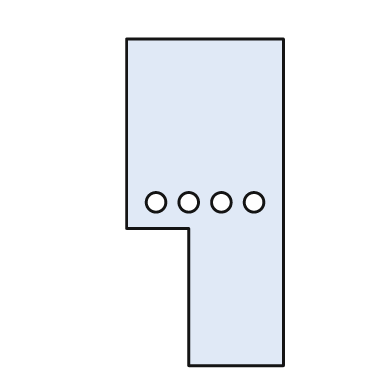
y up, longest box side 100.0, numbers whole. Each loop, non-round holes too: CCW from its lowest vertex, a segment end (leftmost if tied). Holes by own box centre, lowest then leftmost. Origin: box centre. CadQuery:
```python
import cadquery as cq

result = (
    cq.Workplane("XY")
    .moveTo(-5.0, -50.0)
    .lineTo(24.0, -50.0)
    .lineTo(24.0, 50.0)
    .lineTo(-24.0, 50.0)
    .lineTo(-24.0, -8.0)
    .lineTo(-5.0, -8.0)
    .close()
    .moveTo(-15.0, 0.0)
    .circle(3.0)
    .moveTo(-5.0, 0.0)
    .circle(3.0)
    .moveTo(5.0, 0.0)
    .circle(3.0)
    .moveTo(15.0, 0.0)
    .circle(3.0)
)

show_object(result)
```